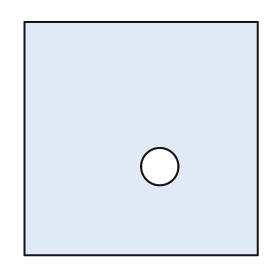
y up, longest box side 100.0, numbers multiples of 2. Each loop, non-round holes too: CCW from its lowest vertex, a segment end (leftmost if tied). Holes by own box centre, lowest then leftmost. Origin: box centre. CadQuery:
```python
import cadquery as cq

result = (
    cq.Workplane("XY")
    .moveTo(-50.0, -50.0)
    .lineTo(50.0, -50.0)
    .lineTo(50.0, 50.0)
    .lineTo(-50.0, 50.0)
    .close()
    .moveTo(8.0, -12.0)
    .circle(8.0)
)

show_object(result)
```